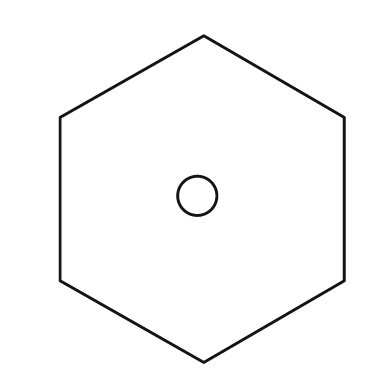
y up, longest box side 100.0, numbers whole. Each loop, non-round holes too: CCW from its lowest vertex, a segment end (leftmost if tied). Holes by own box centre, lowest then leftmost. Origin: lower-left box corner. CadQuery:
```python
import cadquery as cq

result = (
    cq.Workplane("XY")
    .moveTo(44.0, 0.0)
    .lineTo(87.0, 25.0)
    .lineTo(87.0, 75.0)
    .lineTo(44.0, 100.0)
    .lineTo(0.0, 75.0)
    .lineTo(0.0, 25.0)
    .close()
    .moveTo(42.0, 51.0)
    .circle(6.0)
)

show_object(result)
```